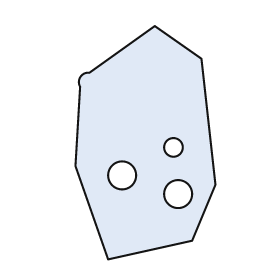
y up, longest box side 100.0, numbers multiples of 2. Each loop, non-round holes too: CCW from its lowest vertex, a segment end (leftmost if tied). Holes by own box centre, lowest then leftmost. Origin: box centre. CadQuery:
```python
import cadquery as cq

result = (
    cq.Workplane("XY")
    .moveTo(-16.0, -50.0)
    .lineTo(20.0, -42.0)
    .lineTo(30.0, -18.0)
    .lineTo(24.0, 36.0)
    .lineTo(4.0, 50.0)
    .lineTo(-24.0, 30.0)
    .threePointArc((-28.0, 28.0), (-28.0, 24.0))
    .lineTo(-30.0, -10.0)
    .close()
    .moveTo(14.0, -22.0)
    .circle(6.0)
    .moveTo(-10.0, -14.0)
    .circle(6.0)
    .moveTo(12.0, -2.0)
    .circle(4.0)
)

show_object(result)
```